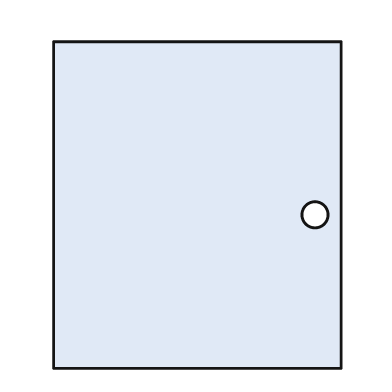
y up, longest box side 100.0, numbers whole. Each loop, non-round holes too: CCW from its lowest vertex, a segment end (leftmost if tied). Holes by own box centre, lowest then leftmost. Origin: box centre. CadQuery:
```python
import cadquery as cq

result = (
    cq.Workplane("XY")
    .moveTo(-44.0, -50.0)
    .lineTo(44.0, -50.0)
    .lineTo(44.0, 50.0)
    .lineTo(-44.0, 50.0)
    .close()
    .moveTo(36.0, -3.0)
    .circle(4.0)
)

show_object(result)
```